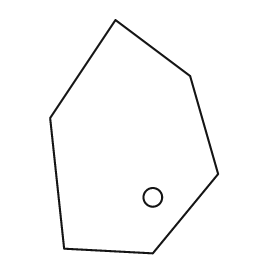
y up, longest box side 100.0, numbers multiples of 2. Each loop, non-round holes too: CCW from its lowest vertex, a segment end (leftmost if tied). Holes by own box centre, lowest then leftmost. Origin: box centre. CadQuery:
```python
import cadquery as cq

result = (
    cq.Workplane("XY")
    .moveTo(8.0, -50.0)
    .lineTo(36.0, -16.0)
    .lineTo(24.0, 26.0)
    .lineTo(-8.0, 50.0)
    .lineTo(-36.0, 8.0)
    .lineTo(-30.0, -48.0)
    .close()
    .moveTo(8.0, -26.0)
    .circle(4.0)
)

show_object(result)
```